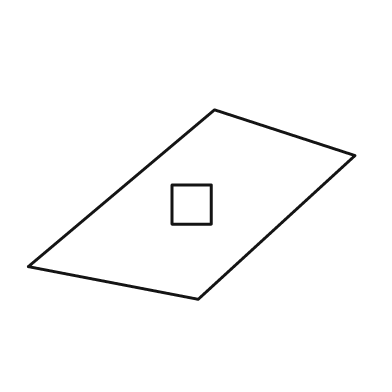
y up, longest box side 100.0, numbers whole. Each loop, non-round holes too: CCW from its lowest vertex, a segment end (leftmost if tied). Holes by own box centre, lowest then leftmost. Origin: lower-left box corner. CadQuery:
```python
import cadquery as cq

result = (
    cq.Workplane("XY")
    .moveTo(52.0, 0.0)
    .lineTo(100.0, 44.0)
    .lineTo(57.0, 58.0)
    .lineTo(0.0, 10.0)
    .close()
    .moveTo(44.0, 23.0)
    .lineTo(56.0, 23.0)
    .lineTo(56.0, 35.0)
    .lineTo(44.0, 35.0)
    .close()
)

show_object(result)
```